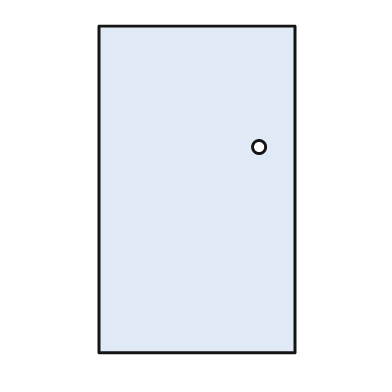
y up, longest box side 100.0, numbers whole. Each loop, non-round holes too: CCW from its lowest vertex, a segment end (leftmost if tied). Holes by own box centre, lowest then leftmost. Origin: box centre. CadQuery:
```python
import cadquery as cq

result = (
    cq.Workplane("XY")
    .moveTo(-30.0, -50.0)
    .lineTo(30.0, -50.0)
    .lineTo(30.0, 50.0)
    .lineTo(-30.0, 50.0)
    .close()
    .moveTo(19.0, 13.0)
    .circle(2.0)
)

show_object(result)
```